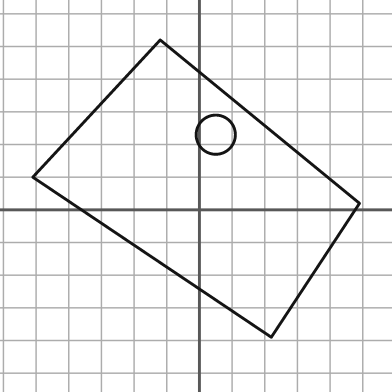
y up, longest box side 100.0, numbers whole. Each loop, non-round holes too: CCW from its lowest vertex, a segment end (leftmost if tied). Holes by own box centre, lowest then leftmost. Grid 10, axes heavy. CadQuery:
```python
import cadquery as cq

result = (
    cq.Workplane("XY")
    .moveTo(22.0, -39.0)
    .lineTo(49.0, 2.0)
    .lineTo(-12.0, 52.0)
    .lineTo(-51.0, 10.0)
    .close()
    .moveTo(5.0, 23.0)
    .circle(6.0)
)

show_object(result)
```